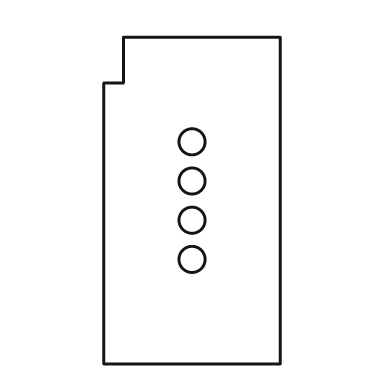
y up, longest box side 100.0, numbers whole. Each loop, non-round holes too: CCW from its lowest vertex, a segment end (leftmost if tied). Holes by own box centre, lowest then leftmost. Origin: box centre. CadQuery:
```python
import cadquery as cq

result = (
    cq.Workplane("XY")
    .moveTo(-27.0, -50.0)
    .lineTo(27.0, -50.0)
    .lineTo(27.0, 50.0)
    .lineTo(-21.0, 50.0)
    .lineTo(-21.0, 36.0)
    .lineTo(-27.0, 36.0)
    .close()
    .moveTo(0.0, -18.0)
    .circle(4.0)
    .moveTo(0.0, -6.0)
    .circle(4.0)
    .moveTo(0.0, 6.0)
    .circle(4.0)
    .moveTo(0.0, 18.0)
    .circle(4.0)
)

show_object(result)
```